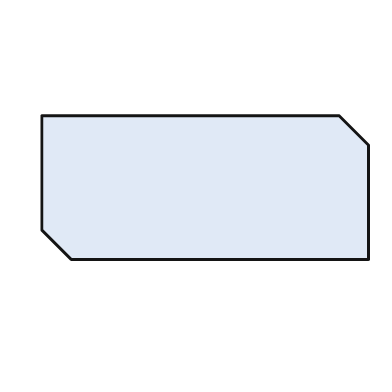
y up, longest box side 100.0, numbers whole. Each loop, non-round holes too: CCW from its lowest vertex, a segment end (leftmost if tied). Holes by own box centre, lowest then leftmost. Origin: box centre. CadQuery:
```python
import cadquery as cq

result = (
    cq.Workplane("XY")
    .moveTo(-41.0, -22.0)
    .lineTo(50.0, -22.0)
    .lineTo(50.0, 13.0)
    .lineTo(41.0, 22.0)
    .lineTo(-50.0, 22.0)
    .lineTo(-50.0, -13.0)
    .close()
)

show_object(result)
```